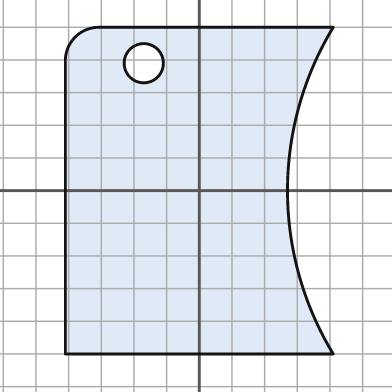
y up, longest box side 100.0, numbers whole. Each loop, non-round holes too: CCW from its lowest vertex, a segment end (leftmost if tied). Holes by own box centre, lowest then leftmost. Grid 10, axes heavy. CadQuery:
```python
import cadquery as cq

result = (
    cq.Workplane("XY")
    .moveTo(-41.0, -50.0)
    .lineTo(41.0, -50.0)
    .threePointArc((27.0, 0.0), (41.0, 50.0))
    .lineTo(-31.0, 50.0)
    .threePointArc((-38.0, 47.0), (-41.0, 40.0))
    .close()
    .moveTo(-17.0, 39.0)
    .circle(6.0)
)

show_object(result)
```